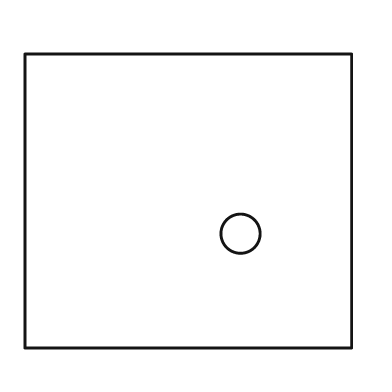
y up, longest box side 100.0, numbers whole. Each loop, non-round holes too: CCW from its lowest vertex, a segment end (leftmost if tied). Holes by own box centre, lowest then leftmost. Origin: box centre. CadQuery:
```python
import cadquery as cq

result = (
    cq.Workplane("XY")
    .moveTo(-50.0, -45.0)
    .lineTo(50.0, -45.0)
    .lineTo(50.0, 45.0)
    .lineTo(-50.0, 45.0)
    .close()
    .moveTo(16.0, -10.0)
    .circle(6.0)
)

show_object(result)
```